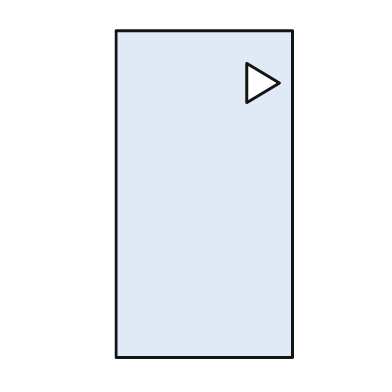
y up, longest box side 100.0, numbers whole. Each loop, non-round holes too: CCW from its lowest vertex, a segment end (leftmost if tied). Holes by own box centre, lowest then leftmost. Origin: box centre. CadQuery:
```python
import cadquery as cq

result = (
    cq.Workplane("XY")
    .moveTo(-27.0, -50.0)
    .lineTo(27.0, -50.0)
    .lineTo(27.0, 50.0)
    .lineTo(-27.0, 50.0)
    .close()
    .moveTo(13.0, 28.0)
    .lineTo(23.0, 34.0)
    .lineTo(13.0, 40.0)
    .close()
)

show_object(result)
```